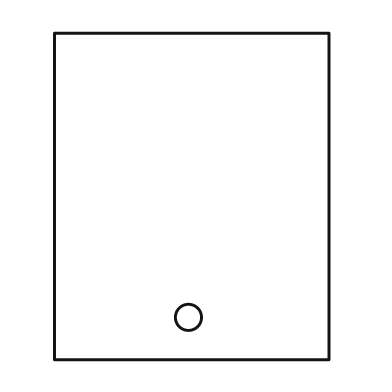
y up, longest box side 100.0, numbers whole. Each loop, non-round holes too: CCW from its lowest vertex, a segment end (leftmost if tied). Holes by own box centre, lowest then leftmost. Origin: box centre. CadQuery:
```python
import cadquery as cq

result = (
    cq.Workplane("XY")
    .moveTo(-42.0, -50.0)
    .lineTo(42.0, -50.0)
    .lineTo(42.0, 50.0)
    .lineTo(-42.0, 50.0)
    .close()
    .moveTo(-1.0, -37.0)
    .circle(4.0)
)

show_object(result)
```